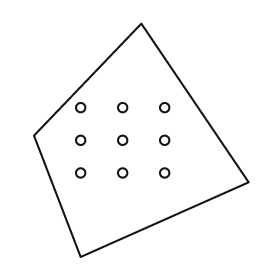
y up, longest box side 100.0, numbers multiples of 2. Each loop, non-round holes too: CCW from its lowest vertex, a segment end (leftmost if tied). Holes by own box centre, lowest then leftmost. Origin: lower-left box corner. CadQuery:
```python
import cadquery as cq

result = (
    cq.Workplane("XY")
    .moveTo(20.0, 0.0)
    .lineTo(92.0, 32.0)
    .lineTo(46.0, 100.0)
    .lineTo(0.0, 52.0)
    .close()
    .moveTo(20.0, 36.0)
    .circle(2.0)
    .moveTo(38.0, 36.0)
    .circle(2.0)
    .moveTo(56.0, 36.0)
    .circle(2.0)
    .moveTo(20.0, 50.0)
    .circle(2.0)
    .moveTo(38.0, 50.0)
    .circle(2.0)
    .moveTo(56.0, 50.0)
    .circle(2.0)
    .moveTo(20.0, 64.0)
    .circle(2.0)
    .moveTo(38.0, 64.0)
    .circle(2.0)
    .moveTo(56.0, 64.0)
    .circle(2.0)
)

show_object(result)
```